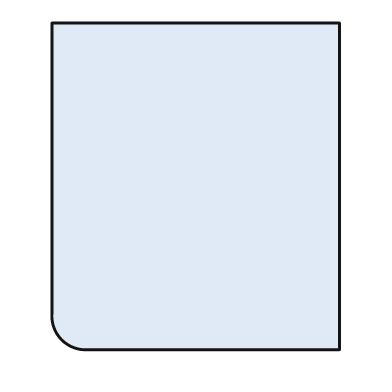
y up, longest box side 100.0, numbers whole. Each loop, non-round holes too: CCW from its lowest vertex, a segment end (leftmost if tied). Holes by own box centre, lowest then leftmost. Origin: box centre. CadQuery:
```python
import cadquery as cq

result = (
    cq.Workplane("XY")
    .moveTo(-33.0, -50.0)
    .lineTo(44.0, -50.0)
    .lineTo(44.0, 50.0)
    .lineTo(-44.0, 50.0)
    .lineTo(-44.0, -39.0)
    .threePointArc((-41.0, -47.0), (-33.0, -50.0))
    .close()
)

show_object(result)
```